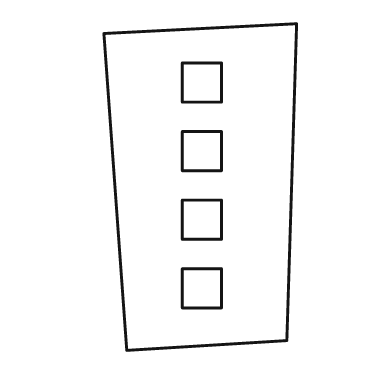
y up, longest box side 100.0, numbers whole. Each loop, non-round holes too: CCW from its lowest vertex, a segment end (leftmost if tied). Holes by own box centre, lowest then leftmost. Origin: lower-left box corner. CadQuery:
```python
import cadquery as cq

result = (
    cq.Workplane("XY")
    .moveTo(7.0, 0.0)
    .lineTo(56.0, 3.0)
    .lineTo(59.0, 100.0)
    .lineTo(0.0, 97.0)
    .close()
    .moveTo(24.0, 13.0)
    .lineTo(36.0, 13.0)
    .lineTo(36.0, 25.0)
    .lineTo(24.0, 25.0)
    .close()
    .moveTo(24.0, 34.0)
    .lineTo(36.0, 34.0)
    .lineTo(36.0, 46.0)
    .lineTo(24.0, 46.0)
    .close()
    .moveTo(24.0, 55.0)
    .lineTo(36.0, 55.0)
    .lineTo(36.0, 67.0)
    .lineTo(24.0, 67.0)
    .close()
    .moveTo(24.0, 76.0)
    .lineTo(36.0, 76.0)
    .lineTo(36.0, 88.0)
    .lineTo(24.0, 88.0)
    .close()
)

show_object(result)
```